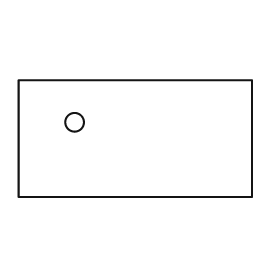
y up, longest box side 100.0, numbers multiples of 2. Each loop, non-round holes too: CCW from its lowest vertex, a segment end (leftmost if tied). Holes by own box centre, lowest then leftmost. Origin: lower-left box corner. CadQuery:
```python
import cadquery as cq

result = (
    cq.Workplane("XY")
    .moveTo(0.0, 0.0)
    .lineTo(100.0, 0.0)
    .lineTo(100.0, 50.0)
    .lineTo(0.0, 50.0)
    .close()
    .moveTo(24.0, 32.0)
    .circle(4.0)
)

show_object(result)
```